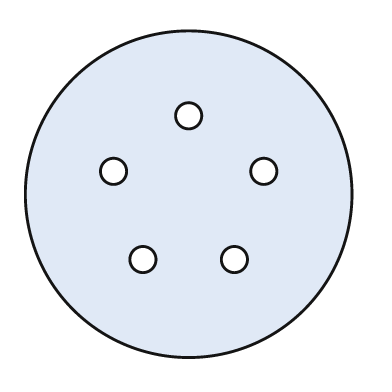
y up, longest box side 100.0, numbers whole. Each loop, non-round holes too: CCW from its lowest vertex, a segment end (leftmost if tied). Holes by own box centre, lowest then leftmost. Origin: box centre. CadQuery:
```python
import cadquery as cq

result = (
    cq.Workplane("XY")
    .moveTo(0.0, 0.0)
    .circle(50.0)
    .moveTo(-14.0, -20.0)
    .circle(4.0)
    .moveTo(14.0, -20.0)
    .circle(4.0)
    .moveTo(-23.0, 7.0)
    .circle(4.0)
    .moveTo(23.0, 7.0)
    .circle(4.0)
    .moveTo(0.0, 24.0)
    .circle(4.0)
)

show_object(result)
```